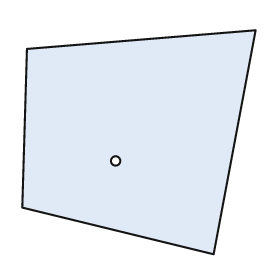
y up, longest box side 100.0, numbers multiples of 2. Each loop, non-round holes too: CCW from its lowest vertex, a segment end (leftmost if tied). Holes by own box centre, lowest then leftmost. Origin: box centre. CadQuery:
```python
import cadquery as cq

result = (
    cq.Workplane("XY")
    .moveTo(32.0, -48.0)
    .lineTo(50.0, 48.0)
    .lineTo(-48.0, 40.0)
    .lineTo(-50.0, -28.0)
    .close()
    .moveTo(-10.0, -8.0)
    .circle(2.0)
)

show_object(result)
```